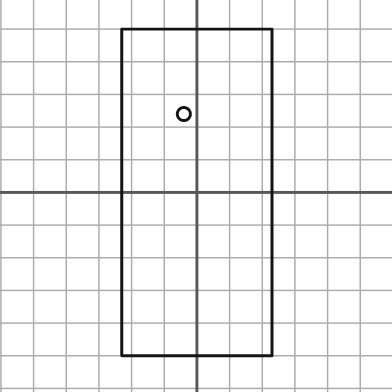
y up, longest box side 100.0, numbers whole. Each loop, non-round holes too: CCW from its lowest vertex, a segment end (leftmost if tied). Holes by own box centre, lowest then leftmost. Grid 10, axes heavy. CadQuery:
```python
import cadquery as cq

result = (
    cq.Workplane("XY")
    .moveTo(-23.0, -50.0)
    .lineTo(23.0, -50.0)
    .lineTo(23.0, 50.0)
    .lineTo(-23.0, 50.0)
    .close()
    .moveTo(-4.0, 24.0)
    .circle(2.0)
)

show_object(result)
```